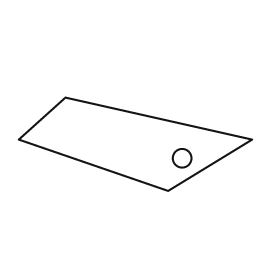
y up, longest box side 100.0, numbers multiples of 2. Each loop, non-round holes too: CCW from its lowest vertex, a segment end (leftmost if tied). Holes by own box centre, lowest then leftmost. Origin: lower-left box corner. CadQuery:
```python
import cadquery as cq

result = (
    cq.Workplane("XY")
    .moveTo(64.0, 0.0)
    .lineTo(100.0, 22.0)
    .lineTo(20.0, 40.0)
    .lineTo(0.0, 22.0)
    .close()
    .moveTo(70.0, 14.0)
    .circle(4.0)
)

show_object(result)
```